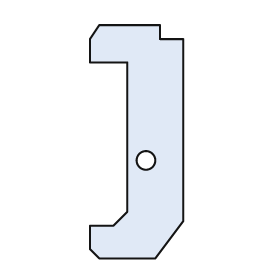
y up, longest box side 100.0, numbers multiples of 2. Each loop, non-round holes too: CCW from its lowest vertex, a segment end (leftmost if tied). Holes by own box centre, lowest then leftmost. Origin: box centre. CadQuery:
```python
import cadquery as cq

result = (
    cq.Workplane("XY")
    .moveTo(-16.0, -50.0)
    .lineTo(8.0, -50.0)
    .lineTo(20.0, -34.0)
    .lineTo(20.0, 44.0)
    .lineTo(10.0, 44.0)
    .lineTo(10.0, 50.0)
    .lineTo(-16.0, 50.0)
    .lineTo(-20.0, 44.0)
    .lineTo(-20.0, 34.0)
    .lineTo(-4.0, 34.0)
    .lineTo(-4.0, -30.0)
    .lineTo(-10.0, -36.0)
    .lineTo(-20.0, -36.0)
    .lineTo(-20.0, -46.0)
    .close()
    .moveTo(4.0, -8.0)
    .circle(4.0)
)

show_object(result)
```